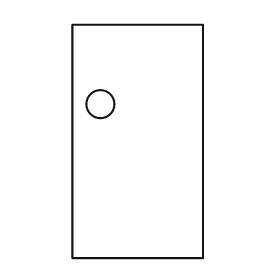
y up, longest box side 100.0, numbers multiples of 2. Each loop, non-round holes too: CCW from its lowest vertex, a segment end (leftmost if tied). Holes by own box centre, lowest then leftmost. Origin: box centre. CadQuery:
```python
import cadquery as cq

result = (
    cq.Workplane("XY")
    .moveTo(-28.0, -50.0)
    .lineTo(28.0, -50.0)
    .lineTo(28.0, 50.0)
    .lineTo(-28.0, 50.0)
    .close()
    .moveTo(-16.0, 16.0)
    .circle(6.0)
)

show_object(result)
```